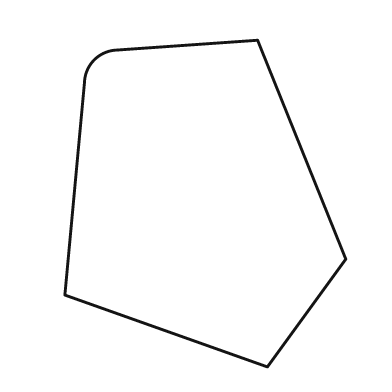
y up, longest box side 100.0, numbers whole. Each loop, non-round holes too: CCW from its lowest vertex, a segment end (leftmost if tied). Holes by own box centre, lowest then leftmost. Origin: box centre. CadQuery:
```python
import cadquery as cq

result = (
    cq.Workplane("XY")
    .moveTo(19.0, -50.0)
    .lineTo(43.0, -17.0)
    .lineTo(16.0, 50.0)
    .lineTo(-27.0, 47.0)
    .threePointArc((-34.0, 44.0), (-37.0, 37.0))
    .lineTo(-43.0, -28.0)
    .close()
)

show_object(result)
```